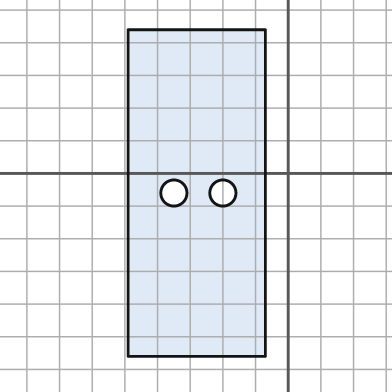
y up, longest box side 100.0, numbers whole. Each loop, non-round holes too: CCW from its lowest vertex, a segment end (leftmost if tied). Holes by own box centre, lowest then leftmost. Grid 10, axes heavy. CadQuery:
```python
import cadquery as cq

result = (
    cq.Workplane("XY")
    .moveTo(-49.0, -56.0)
    .lineTo(-7.0, -56.0)
    .lineTo(-7.0, 44.0)
    .lineTo(-49.0, 44.0)
    .close()
    .moveTo(-35.0, -6.0)
    .circle(4.0)
    .moveTo(-20.0, -6.0)
    .circle(4.0)
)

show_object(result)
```